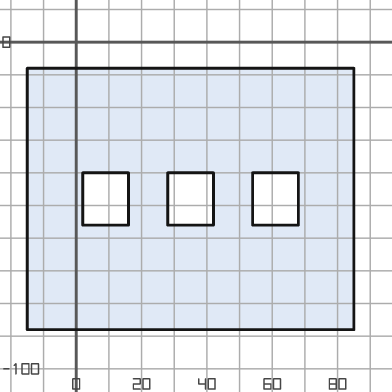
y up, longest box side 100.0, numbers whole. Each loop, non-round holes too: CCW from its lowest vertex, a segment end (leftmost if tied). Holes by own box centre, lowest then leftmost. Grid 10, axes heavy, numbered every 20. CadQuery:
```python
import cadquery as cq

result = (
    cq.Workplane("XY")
    .moveTo(-15.0, -88.0)
    .lineTo(85.0, -88.0)
    .lineTo(85.0, -8.0)
    .lineTo(-15.0, -8.0)
    .close()
    .moveTo(2.0, -56.0)
    .lineTo(16.0, -56.0)
    .lineTo(16.0, -40.0)
    .lineTo(2.0, -40.0)
    .close()
    .moveTo(28.0, -56.0)
    .lineTo(42.0, -56.0)
    .lineTo(42.0, -40.0)
    .lineTo(28.0, -40.0)
    .close()
    .moveTo(54.0, -56.0)
    .lineTo(68.0, -56.0)
    .lineTo(68.0, -40.0)
    .lineTo(54.0, -40.0)
    .close()
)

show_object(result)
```